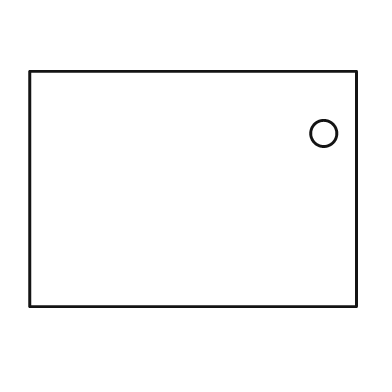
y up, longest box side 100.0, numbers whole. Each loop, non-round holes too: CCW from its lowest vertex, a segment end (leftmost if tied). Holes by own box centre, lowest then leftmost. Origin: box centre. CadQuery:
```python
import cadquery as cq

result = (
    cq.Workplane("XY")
    .moveTo(-50.0, -36.0)
    .lineTo(50.0, -36.0)
    .lineTo(50.0, 36.0)
    .lineTo(-50.0, 36.0)
    .close()
    .moveTo(40.0, 17.0)
    .circle(4.0)
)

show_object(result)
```